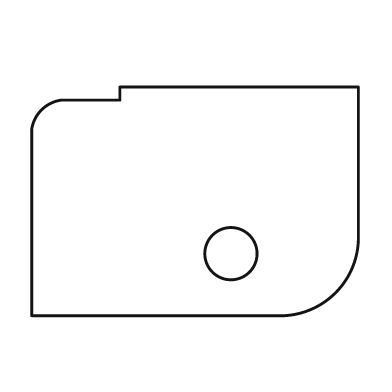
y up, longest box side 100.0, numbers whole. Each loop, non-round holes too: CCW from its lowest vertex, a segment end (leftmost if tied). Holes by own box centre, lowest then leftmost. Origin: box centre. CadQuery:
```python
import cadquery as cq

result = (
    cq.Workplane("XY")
    .moveTo(-50.0, -35.0)
    .lineTo(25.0, -35.0)
    .threePointArc((43.0, -28.0), (50.0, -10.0))
    .lineTo(50.0, 35.0)
    .lineTo(-23.0, 35.0)
    .lineTo(-23.0, 31.0)
    .lineTo(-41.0, 31.0)
    .threePointArc((-47.0, 28.0), (-50.0, 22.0))
    .close()
    .moveTo(11.0, -16.0)
    .circle(8.0)
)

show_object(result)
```